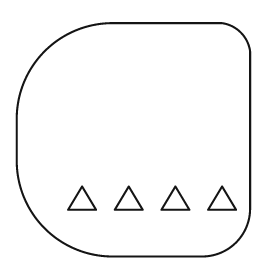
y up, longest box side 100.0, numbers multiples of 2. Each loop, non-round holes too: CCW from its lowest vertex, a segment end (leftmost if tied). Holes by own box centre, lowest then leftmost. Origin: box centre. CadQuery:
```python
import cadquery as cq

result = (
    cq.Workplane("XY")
    .moveTo(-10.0, -50.0)
    .lineTo(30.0, -50.0)
    .threePointArc((44.0, -44.0), (50.0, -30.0))
    .lineTo(50.0, 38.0)
    .threePointArc((46.0, 46.0), (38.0, 50.0))
    .lineTo(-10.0, 50.0)
    .threePointArc((-38.0, 38.0), (-50.0, 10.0))
    .lineTo(-50.0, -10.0)
    .threePointArc((-38.0, -38.0), (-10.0, -50.0))
    .close()
    .moveTo(-28.0, -30.0)
    .lineTo(-16.0, -30.0)
    .lineTo(-22.0, -20.0)
    .close()
    .moveTo(-8.0, -30.0)
    .lineTo(4.0, -30.0)
    .lineTo(-2.0, -20.0)
    .close()
    .moveTo(12.0, -30.0)
    .lineTo(24.0, -30.0)
    .lineTo(18.0, -20.0)
    .close()
    .moveTo(32.0, -30.0)
    .lineTo(44.0, -30.0)
    .lineTo(38.0, -20.0)
    .close()
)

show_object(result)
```